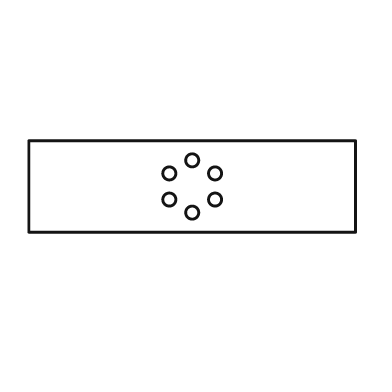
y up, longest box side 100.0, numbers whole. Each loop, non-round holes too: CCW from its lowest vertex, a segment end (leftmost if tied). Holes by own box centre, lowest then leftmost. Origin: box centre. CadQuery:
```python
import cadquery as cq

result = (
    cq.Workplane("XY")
    .moveTo(-50.0, -14.0)
    .lineTo(50.0, -14.0)
    .lineTo(50.0, 14.0)
    .lineTo(-50.0, 14.0)
    .close()
    .moveTo(0.0, -8.0)
    .circle(2.0)
    .moveTo(-7.0, -4.0)
    .circle(2.0)
    .moveTo(7.0, -4.0)
    .circle(2.0)
    .moveTo(-7.0, 4.0)
    .circle(2.0)
    .moveTo(7.0, 4.0)
    .circle(2.0)
    .moveTo(0.0, 8.0)
    .circle(2.0)
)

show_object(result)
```